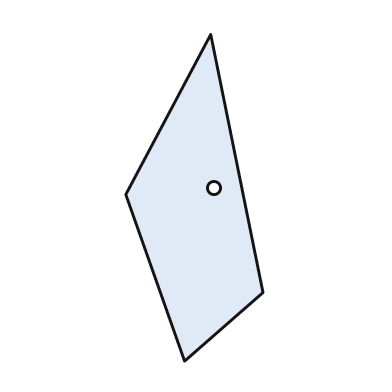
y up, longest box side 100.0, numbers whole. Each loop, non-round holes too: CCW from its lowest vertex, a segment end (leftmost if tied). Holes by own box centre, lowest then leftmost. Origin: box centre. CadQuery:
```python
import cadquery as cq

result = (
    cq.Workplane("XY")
    .moveTo(-3.0, -50.0)
    .lineTo(21.0, -29.0)
    .lineTo(5.0, 50.0)
    .lineTo(-21.0, 1.0)
    .close()
    .moveTo(6.0, 3.0)
    .circle(2.0)
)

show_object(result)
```